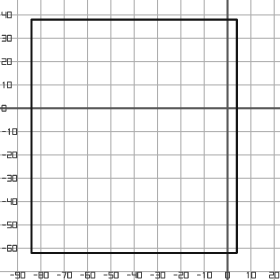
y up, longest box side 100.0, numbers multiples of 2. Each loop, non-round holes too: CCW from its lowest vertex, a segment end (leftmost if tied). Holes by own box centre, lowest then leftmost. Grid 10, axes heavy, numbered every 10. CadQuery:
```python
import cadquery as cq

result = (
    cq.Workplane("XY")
    .moveTo(-84.0, -62.0)
    .lineTo(4.0, -62.0)
    .lineTo(4.0, 38.0)
    .lineTo(-84.0, 38.0)
    .close()
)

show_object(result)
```